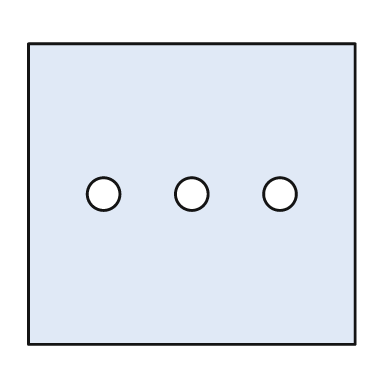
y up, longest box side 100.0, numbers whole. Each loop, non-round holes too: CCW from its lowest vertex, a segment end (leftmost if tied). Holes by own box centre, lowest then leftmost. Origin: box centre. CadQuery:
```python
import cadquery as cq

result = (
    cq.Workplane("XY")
    .moveTo(-50.0, -46.0)
    .lineTo(50.0, -46.0)
    .lineTo(50.0, 46.0)
    .lineTo(-50.0, 46.0)
    .close()
    .moveTo(-27.0, 0.0)
    .circle(5.0)
    .moveTo(0.0, 0.0)
    .circle(5.0)
    .moveTo(27.0, 0.0)
    .circle(5.0)
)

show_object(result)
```